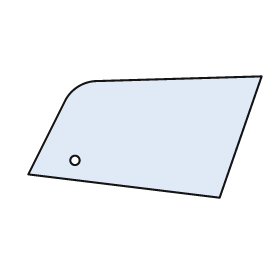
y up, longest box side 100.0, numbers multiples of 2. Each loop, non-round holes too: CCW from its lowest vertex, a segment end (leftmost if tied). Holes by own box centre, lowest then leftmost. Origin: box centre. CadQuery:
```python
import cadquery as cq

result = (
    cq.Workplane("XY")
    .moveTo(32.0, -26.0)
    .lineTo(50.0, 26.0)
    .lineTo(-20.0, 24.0)
    .threePointArc((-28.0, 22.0), (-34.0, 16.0))
    .lineTo(-50.0, -16.0)
    .close()
    .moveTo(-30.0, -10.0)
    .circle(2.0)
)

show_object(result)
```